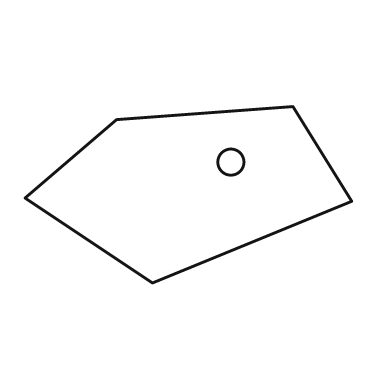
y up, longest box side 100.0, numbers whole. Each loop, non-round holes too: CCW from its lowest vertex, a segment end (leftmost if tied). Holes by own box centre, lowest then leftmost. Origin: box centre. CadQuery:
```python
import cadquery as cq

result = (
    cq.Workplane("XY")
    .moveTo(-11.0, -27.0)
    .lineTo(50.0, -2.0)
    .lineTo(32.0, 27.0)
    .lineTo(-22.0, 23.0)
    .lineTo(-50.0, -1.0)
    .close()
    .moveTo(13.0, 10.0)
    .circle(4.0)
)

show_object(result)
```